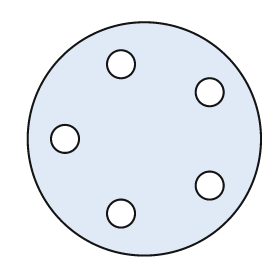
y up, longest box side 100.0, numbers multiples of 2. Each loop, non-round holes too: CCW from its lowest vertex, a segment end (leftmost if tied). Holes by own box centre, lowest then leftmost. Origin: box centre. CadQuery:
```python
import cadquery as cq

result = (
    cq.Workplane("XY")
    .moveTo(0.0, 0.0)
    .circle(50.0)
    .moveTo(-10.0, -32.0)
    .circle(6.0)
    .moveTo(28.0, -20.0)
    .circle(6.0)
    .moveTo(-34.0, 0.0)
    .circle(6.0)
    .moveTo(28.0, 20.0)
    .circle(6.0)
    .moveTo(-10.0, 32.0)
    .circle(6.0)
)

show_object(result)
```